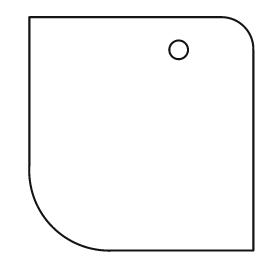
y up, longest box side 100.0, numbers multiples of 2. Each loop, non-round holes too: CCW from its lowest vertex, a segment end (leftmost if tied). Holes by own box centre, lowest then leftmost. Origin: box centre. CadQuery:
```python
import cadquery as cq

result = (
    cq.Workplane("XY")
    .moveTo(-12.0, -50.0)
    .lineTo(48.0, -50.0)
    .lineTo(48.0, 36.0)
    .threePointArc((44.0, 46.0), (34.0, 50.0))
    .lineTo(-48.0, 50.0)
    .lineTo(-48.0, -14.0)
    .threePointArc((-38.0, -40.0), (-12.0, -50.0))
    .close()
    .moveTo(16.0, 36.0)
    .circle(4.0)
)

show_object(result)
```